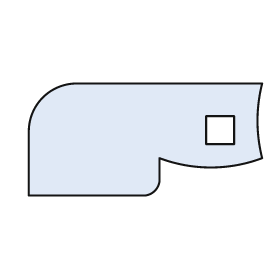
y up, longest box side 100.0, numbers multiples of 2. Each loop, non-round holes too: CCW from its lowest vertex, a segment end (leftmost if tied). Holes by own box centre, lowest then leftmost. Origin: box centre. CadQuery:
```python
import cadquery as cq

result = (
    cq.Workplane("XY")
    .moveTo(-50.0, -24.0)
    .lineTo(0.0, -24.0)
    .threePointArc((4.0, -22.0), (6.0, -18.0))
    .lineTo(6.0, -8.0)
    .threePointArc((28.0, -12.0), (50.0, -8.0))
    .threePointArc((48.0, 8.0), (50.0, 24.0))
    .lineTo(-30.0, 24.0)
    .threePointArc((-44.0, 18.0), (-50.0, 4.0))
    .close()
    .moveTo(26.0, -2.0)
    .lineTo(38.0, -2.0)
    .lineTo(38.0, 10.0)
    .lineTo(26.0, 10.0)
    .close()
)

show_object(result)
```